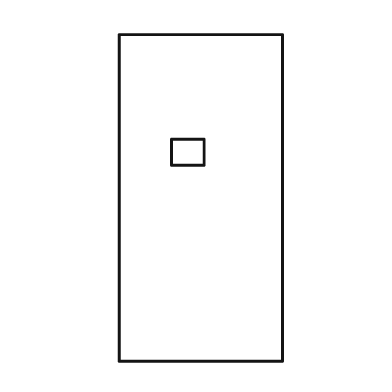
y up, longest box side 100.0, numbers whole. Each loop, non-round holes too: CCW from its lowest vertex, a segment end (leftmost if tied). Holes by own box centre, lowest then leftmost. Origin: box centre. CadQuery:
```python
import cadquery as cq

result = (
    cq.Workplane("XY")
    .moveTo(-25.0, -50.0)
    .lineTo(25.0, -50.0)
    .lineTo(25.0, 50.0)
    .lineTo(-25.0, 50.0)
    .close()
    .moveTo(-9.0, 10.0)
    .lineTo(1.0, 10.0)
    .lineTo(1.0, 18.0)
    .lineTo(-9.0, 18.0)
    .close()
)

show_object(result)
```